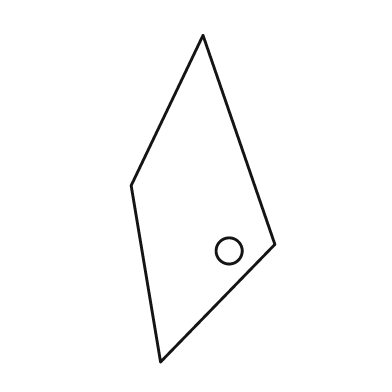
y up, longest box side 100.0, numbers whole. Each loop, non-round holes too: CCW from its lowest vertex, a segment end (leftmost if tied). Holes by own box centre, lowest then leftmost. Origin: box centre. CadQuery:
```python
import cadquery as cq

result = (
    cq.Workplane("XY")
    .moveTo(-13.0, -50.0)
    .lineTo(22.0, -14.0)
    .lineTo(0.0, 50.0)
    .lineTo(-22.0, 4.0)
    .close()
    .moveTo(8.0, -16.0)
    .circle(4.0)
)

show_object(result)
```